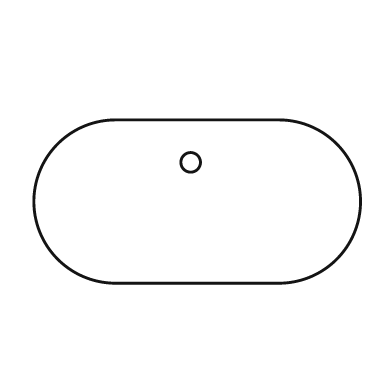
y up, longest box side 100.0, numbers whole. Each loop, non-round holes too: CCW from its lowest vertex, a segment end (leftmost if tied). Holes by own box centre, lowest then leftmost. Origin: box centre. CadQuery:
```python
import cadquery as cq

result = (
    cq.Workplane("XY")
    .moveTo(-25.0, -25.0)
    .lineTo(25.0, -25.0)
    .threePointArc((50.0, 0.0), (25.0, 25.0))
    .lineTo(-25.0, 25.0)
    .threePointArc((-50.0, 0.0), (-25.0, -25.0))
    .close()
    .moveTo(-2.0, 12.0)
    .circle(3.0)
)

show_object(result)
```